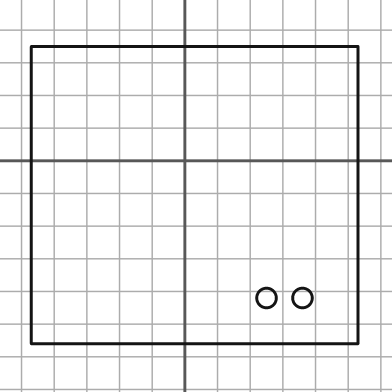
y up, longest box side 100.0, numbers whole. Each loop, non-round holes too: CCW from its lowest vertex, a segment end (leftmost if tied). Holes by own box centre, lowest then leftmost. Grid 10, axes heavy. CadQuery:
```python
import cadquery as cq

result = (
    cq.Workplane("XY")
    .moveTo(-47.0, -56.0)
    .lineTo(53.0, -56.0)
    .lineTo(53.0, 35.0)
    .lineTo(-47.0, 35.0)
    .close()
    .moveTo(25.0, -42.0)
    .circle(3.0)
    .moveTo(36.0, -42.0)
    .circle(3.0)
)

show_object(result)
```